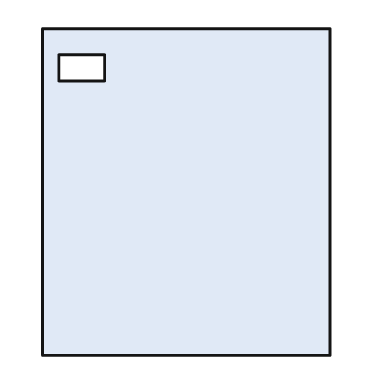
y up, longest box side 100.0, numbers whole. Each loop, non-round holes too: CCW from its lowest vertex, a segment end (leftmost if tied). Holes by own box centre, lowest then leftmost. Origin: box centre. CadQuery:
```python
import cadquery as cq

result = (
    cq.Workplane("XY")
    .moveTo(-44.0, -50.0)
    .lineTo(44.0, -50.0)
    .lineTo(44.0, 50.0)
    .lineTo(-44.0, 50.0)
    .close()
    .moveTo(-39.0, 34.0)
    .lineTo(-25.0, 34.0)
    .lineTo(-25.0, 42.0)
    .lineTo(-39.0, 42.0)
    .close()
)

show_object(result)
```